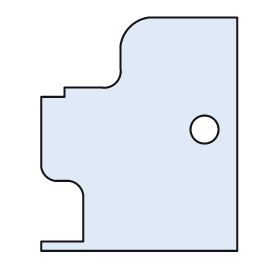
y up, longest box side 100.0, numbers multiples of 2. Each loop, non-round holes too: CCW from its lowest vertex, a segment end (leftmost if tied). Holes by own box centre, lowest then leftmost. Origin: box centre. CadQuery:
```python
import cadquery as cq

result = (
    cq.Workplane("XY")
    .moveTo(-42.0, -50.0)
    .lineTo(42.0, -50.0)
    .lineTo(42.0, 50.0)
    .lineTo(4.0, 50.0)
    .threePointArc((-4.0, 46.0), (-8.0, 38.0))
    .lineTo(-8.0, 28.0)
    .threePointArc((-10.0, 22.0), (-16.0, 20.0))
    .lineTo(-32.0, 20.0)
    .lineTo(-32.0, 16.0)
    .lineTo(-42.0, 16.0)
    .lineTo(-42.0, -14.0)
    .threePointArc((-40.0, -18.0), (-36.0, -20.0))
    .lineTo(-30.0, -20.0)
    .threePointArc((-26.0, -22.0), (-24.0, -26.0))
    .lineTo(-24.0, -46.0)
    .lineTo(-42.0, -46.0)
    .close()
    .moveTo(28.0, 2.0)
    .circle(6.0)
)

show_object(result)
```